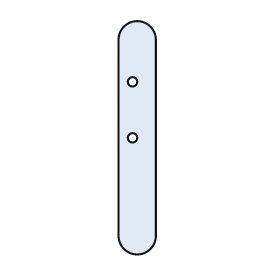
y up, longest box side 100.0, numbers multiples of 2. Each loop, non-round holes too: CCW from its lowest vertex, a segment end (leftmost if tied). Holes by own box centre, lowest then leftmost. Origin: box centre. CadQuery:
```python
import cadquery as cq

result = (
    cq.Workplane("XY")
    .moveTo(-8.0, -42.0)
    .threePointArc((0.0, -50.0), (8.0, -42.0))
    .lineTo(8.0, 42.0)
    .threePointArc((0.0, 50.0), (-8.0, 42.0))
    .close()
    .moveTo(-2.0, 0.0)
    .circle(2.0)
    .moveTo(-2.0, 24.0)
    .circle(2.0)
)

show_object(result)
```